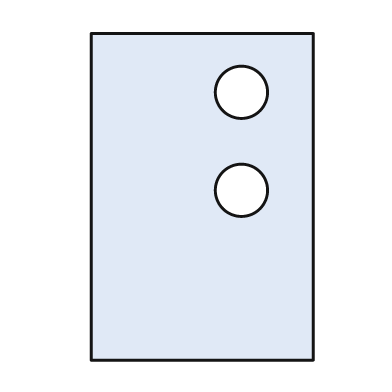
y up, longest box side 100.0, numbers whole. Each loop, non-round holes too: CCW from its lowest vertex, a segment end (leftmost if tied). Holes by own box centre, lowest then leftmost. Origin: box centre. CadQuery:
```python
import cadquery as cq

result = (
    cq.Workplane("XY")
    .moveTo(-34.0, -50.0)
    .lineTo(34.0, -50.0)
    .lineTo(34.0, 50.0)
    .lineTo(-34.0, 50.0)
    .close()
    .moveTo(12.0, 2.0)
    .circle(8.0)
    .moveTo(12.0, 32.0)
    .circle(8.0)
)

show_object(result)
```